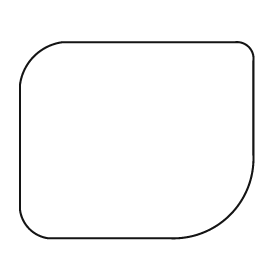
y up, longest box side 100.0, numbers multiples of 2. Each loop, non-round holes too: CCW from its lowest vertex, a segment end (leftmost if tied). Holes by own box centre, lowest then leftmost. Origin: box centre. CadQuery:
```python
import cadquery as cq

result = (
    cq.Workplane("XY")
    .moveTo(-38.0, -42.0)
    .lineTo(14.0, -42.0)
    .threePointArc((40.0, -32.0), (50.0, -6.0))
    .lineTo(50.0, 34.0)
    .threePointArc((48.0, 40.0), (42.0, 42.0))
    .lineTo(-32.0, 42.0)
    .threePointArc((-44.0, 36.0), (-50.0, 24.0))
    .lineTo(-50.0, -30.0)
    .threePointArc((-46.0, -38.0), (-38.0, -42.0))
    .close()
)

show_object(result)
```